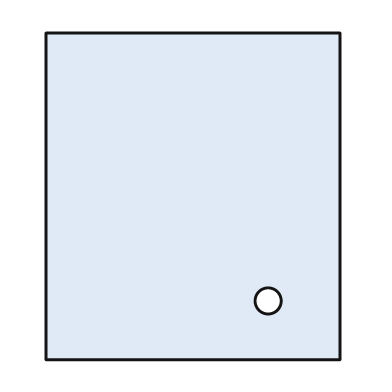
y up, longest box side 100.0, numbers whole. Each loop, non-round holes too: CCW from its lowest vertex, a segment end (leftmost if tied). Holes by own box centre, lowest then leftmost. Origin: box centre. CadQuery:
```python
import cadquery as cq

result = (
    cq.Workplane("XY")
    .moveTo(-45.0, -50.0)
    .lineTo(45.0, -50.0)
    .lineTo(45.0, 50.0)
    .lineTo(-45.0, 50.0)
    .close()
    .moveTo(23.0, -32.0)
    .circle(4.0)
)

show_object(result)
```